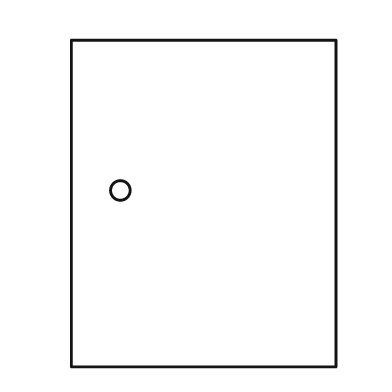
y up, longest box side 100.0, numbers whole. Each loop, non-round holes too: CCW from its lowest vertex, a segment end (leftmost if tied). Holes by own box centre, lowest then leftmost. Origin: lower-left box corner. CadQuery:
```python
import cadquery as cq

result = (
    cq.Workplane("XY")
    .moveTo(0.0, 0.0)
    .lineTo(81.0, 0.0)
    .lineTo(81.0, 100.0)
    .lineTo(0.0, 100.0)
    .close()
    .moveTo(15.0, 54.0)
    .circle(3.0)
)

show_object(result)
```